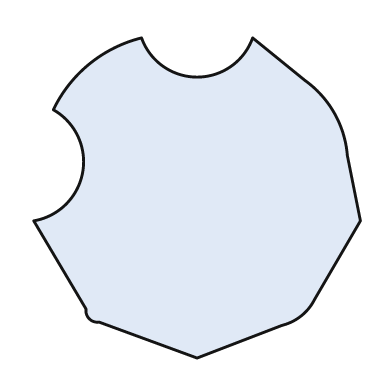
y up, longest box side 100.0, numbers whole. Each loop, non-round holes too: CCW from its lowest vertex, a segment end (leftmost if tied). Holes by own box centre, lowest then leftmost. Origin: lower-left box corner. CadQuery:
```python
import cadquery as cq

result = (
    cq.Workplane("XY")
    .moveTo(50.0, 0.0)
    .lineTo(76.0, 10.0)
    .threePointArc((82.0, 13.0), (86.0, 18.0))
    .lineTo(100.0, 42.0)
    .lineTo(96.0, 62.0)
    .threePointArc((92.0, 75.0), (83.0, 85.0))
    .lineTo(67.0, 98.0)
    .threePointArc((50.0, 86.0), (33.0, 98.0))
    .threePointArc((17.0, 90.0), (6.0, 76.0))
    .threePointArc((15.0, 57.0), (0.0, 42.0))
    .lineTo(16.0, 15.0)
    .threePointArc((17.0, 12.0), (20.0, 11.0))
    .close()
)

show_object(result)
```